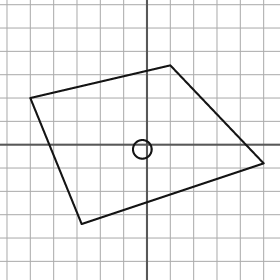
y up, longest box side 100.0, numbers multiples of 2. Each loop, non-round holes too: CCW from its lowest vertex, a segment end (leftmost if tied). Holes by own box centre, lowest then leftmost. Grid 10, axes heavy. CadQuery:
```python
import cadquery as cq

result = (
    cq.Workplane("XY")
    .moveTo(-28.0, -34.0)
    .lineTo(50.0, -8.0)
    .lineTo(10.0, 34.0)
    .lineTo(-50.0, 20.0)
    .close()
    .moveTo(-2.0, -2.0)
    .circle(4.0)
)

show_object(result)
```